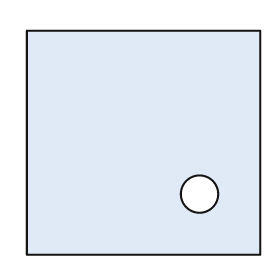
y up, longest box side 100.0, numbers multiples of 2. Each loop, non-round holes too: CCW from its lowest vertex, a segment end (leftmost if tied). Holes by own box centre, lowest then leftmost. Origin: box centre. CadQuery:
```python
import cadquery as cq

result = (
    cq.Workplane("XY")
    .moveTo(-50.0, -48.0)
    .lineTo(50.0, -48.0)
    .lineTo(50.0, 48.0)
    .lineTo(-50.0, 48.0)
    .close()
    .moveTo(24.0, -22.0)
    .circle(8.0)
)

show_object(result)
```